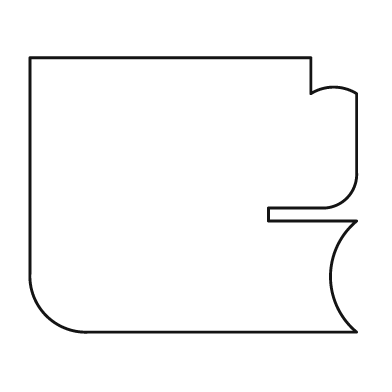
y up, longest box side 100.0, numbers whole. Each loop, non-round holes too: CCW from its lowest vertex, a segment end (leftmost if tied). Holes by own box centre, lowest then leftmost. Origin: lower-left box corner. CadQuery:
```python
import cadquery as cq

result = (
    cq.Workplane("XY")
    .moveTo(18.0, 0.0)
    .lineTo(100.0, 0.0)
    .threePointArc((92.0, 17.0), (100.0, 34.0))
    .lineTo(73.0, 34.0)
    .lineTo(73.0, 38.0)
    .lineTo(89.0, 38.0)
    .threePointArc((97.0, 41.0), (100.0, 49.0))
    .lineTo(100.0, 73.0)
    .threePointArc((93.0, 75.0), (86.0, 73.0))
    .lineTo(86.0, 84.0)
    .lineTo(0.0, 84.0)
    .lineTo(0.0, 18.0)
    .threePointArc((5.0, 5.0), (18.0, 0.0))
    .close()
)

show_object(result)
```